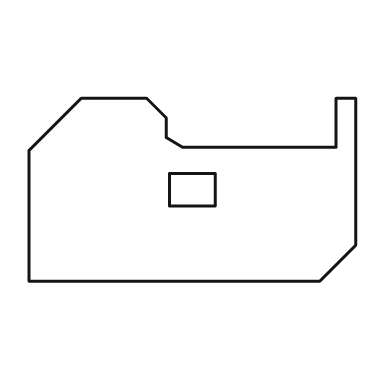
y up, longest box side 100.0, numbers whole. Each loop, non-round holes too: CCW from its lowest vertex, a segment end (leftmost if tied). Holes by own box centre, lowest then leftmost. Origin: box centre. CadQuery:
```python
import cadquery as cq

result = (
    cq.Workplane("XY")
    .moveTo(-50.0, -28.0)
    .lineTo(39.0, -28.0)
    .lineTo(50.0, -17.0)
    .lineTo(50.0, 28.0)
    .lineTo(44.0, 28.0)
    .lineTo(44.0, 13.0)
    .lineTo(-3.0, 13.0)
    .lineTo(-8.0, 16.0)
    .lineTo(-8.0, 22.0)
    .lineTo(-14.0, 28.0)
    .lineTo(-34.0, 28.0)
    .lineTo(-50.0, 12.0)
    .close()
    .moveTo(-7.0, -5.0)
    .lineTo(7.0, -5.0)
    .lineTo(7.0, 5.0)
    .lineTo(-7.0, 5.0)
    .close()
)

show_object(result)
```